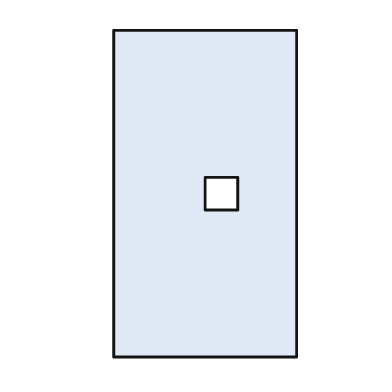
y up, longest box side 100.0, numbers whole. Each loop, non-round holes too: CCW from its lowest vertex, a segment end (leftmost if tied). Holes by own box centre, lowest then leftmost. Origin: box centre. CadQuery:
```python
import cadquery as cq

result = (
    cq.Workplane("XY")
    .moveTo(-28.0, -50.0)
    .lineTo(28.0, -50.0)
    .lineTo(28.0, 50.0)
    .lineTo(-28.0, 50.0)
    .close()
    .moveTo(0.0, -5.0)
    .lineTo(10.0, -5.0)
    .lineTo(10.0, 5.0)
    .lineTo(0.0, 5.0)
    .close()
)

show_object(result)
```